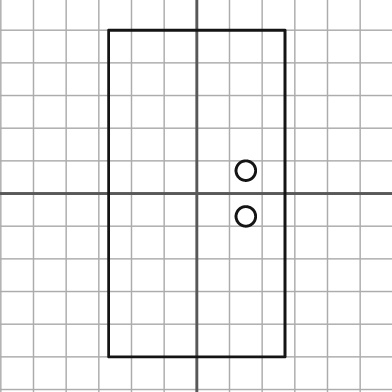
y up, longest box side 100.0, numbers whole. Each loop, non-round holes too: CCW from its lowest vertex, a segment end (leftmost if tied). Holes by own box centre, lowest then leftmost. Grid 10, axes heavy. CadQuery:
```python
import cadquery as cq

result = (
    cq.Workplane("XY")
    .moveTo(-27.0, -50.0)
    .lineTo(27.0, -50.0)
    .lineTo(27.0, 50.0)
    .lineTo(-27.0, 50.0)
    .close()
    .moveTo(15.0, -7.0)
    .circle(3.0)
    .moveTo(15.0, 7.0)
    .circle(3.0)
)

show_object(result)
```